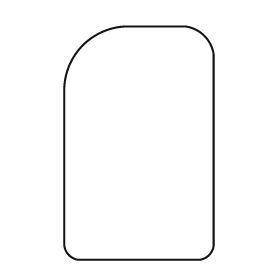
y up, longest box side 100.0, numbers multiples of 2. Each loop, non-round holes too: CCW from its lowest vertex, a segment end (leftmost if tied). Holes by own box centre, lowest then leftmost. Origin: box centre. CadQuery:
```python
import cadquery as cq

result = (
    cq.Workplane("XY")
    .moveTo(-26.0, -50.0)
    .lineTo(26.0, -50.0)
    .threePointArc((30.0, -48.0), (32.0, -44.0))
    .lineTo(32.0, 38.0)
    .threePointArc((28.0, 46.0), (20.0, 50.0))
    .lineTo(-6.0, 50.0)
    .threePointArc((-24.0, 42.0), (-32.0, 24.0))
    .lineTo(-32.0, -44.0)
    .threePointArc((-30.0, -48.0), (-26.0, -50.0))
    .close()
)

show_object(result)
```